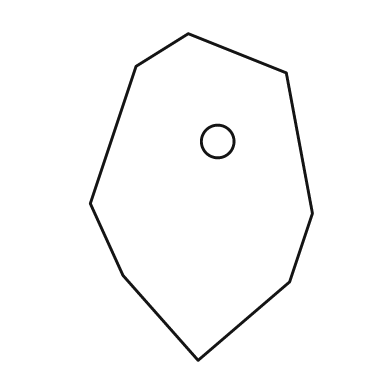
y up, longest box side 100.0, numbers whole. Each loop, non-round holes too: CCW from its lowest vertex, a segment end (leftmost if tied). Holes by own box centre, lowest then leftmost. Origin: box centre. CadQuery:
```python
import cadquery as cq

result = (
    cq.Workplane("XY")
    .moveTo(-1.0, -50.0)
    .lineTo(27.0, -26.0)
    .lineTo(34.0, -5.0)
    .lineTo(26.0, 38.0)
    .lineTo(-4.0, 50.0)
    .lineTo(-20.0, 40.0)
    .lineTo(-34.0, -2.0)
    .lineTo(-24.0, -24.0)
    .close()
    .moveTo(5.0, 17.0)
    .circle(5.0)
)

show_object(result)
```